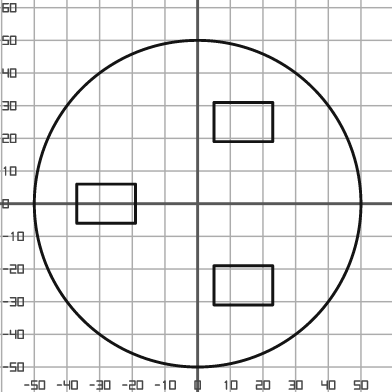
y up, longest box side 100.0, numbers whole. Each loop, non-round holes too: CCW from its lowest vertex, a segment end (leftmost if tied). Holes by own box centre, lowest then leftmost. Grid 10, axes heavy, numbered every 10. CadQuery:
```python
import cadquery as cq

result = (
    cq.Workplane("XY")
    .moveTo(0.0, 0.0)
    .circle(50.0)
    .moveTo(5.0, -31.0)
    .lineTo(23.0, -31.0)
    .lineTo(23.0, -19.0)
    .lineTo(5.0, -19.0)
    .close()
    .moveTo(-37.0, -6.0)
    .lineTo(-19.0, -6.0)
    .lineTo(-19.0, 6.0)
    .lineTo(-37.0, 6.0)
    .close()
    .moveTo(5.0, 19.0)
    .lineTo(23.0, 19.0)
    .lineTo(23.0, 31.0)
    .lineTo(5.0, 31.0)
    .close()
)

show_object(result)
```